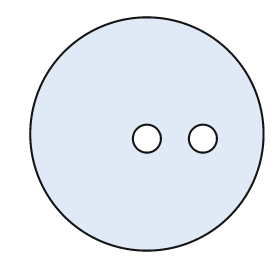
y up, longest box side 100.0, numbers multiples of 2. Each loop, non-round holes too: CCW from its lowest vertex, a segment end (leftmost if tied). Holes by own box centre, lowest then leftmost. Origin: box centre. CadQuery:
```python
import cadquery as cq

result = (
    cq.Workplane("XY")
    .moveTo(0.0, 0.0)
    .circle(50.0)
    .moveTo(0.0, -2.0)
    .circle(6.0)
    .moveTo(24.0, -2.0)
    .circle(6.0)
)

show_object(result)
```